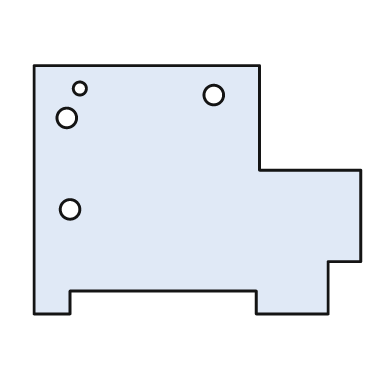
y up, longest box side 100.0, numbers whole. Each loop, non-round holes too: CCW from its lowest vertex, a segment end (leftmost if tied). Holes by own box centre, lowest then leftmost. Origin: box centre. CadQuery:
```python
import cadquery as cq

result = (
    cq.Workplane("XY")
    .moveTo(-50.0, -38.0)
    .lineTo(-39.0, -38.0)
    .lineTo(-39.0, -31.0)
    .lineTo(18.0, -31.0)
    .lineTo(18.0, -38.0)
    .lineTo(40.0, -38.0)
    .lineTo(40.0, -22.0)
    .lineTo(50.0, -22.0)
    .lineTo(50.0, 6.0)
    .lineTo(19.0, 6.0)
    .lineTo(19.0, 38.0)
    .lineTo(-50.0, 38.0)
    .close()
    .moveTo(-39.0, -6.0)
    .circle(3.0)
    .moveTo(-40.0, 22.0)
    .circle(3.0)
    .moveTo(5.0, 29.0)
    .circle(3.0)
    .moveTo(-36.0, 31.0)
    .circle(2.0)
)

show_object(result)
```